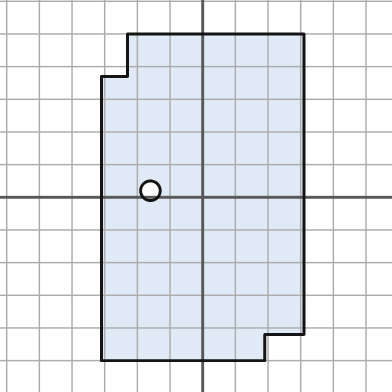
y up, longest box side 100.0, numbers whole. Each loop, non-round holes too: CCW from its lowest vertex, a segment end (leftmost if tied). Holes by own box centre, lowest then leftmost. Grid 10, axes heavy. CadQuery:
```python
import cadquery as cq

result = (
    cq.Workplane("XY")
    .moveTo(-31.0, -50.0)
    .lineTo(19.0, -50.0)
    .lineTo(19.0, -42.0)
    .lineTo(31.0, -42.0)
    .lineTo(31.0, 50.0)
    .lineTo(-23.0, 50.0)
    .lineTo(-23.0, 37.0)
    .lineTo(-31.0, 37.0)
    .close()
    .moveTo(-16.0, 2.0)
    .circle(3.0)
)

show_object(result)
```